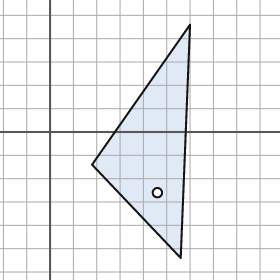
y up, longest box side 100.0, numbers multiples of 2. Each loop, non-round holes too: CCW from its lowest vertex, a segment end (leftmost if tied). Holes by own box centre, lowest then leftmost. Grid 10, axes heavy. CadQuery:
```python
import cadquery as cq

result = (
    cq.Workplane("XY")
    .moveTo(56.0, -54.0)
    .lineTo(60.0, 46.0)
    .lineTo(18.0, -14.0)
    .close()
    .moveTo(46.0, -26.0)
    .circle(2.0)
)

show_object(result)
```